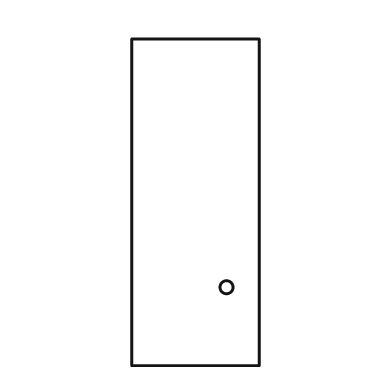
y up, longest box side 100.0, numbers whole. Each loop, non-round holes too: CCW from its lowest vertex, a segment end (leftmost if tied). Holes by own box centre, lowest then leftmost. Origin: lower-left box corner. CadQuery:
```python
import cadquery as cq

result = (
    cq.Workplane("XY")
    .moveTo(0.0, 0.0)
    .lineTo(39.0, 0.0)
    .lineTo(39.0, 100.0)
    .lineTo(0.0, 100.0)
    .close()
    .moveTo(29.0, 24.0)
    .circle(2.0)
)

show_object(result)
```